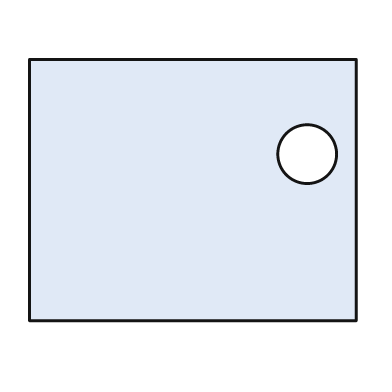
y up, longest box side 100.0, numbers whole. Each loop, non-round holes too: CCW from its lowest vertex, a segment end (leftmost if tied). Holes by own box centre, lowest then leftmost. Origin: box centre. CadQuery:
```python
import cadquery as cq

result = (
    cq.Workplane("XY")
    .moveTo(-50.0, -40.0)
    .lineTo(50.0, -40.0)
    .lineTo(50.0, 40.0)
    .lineTo(-50.0, 40.0)
    .close()
    .moveTo(35.0, 11.0)
    .circle(9.0)
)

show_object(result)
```